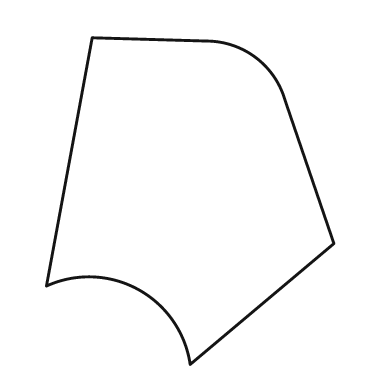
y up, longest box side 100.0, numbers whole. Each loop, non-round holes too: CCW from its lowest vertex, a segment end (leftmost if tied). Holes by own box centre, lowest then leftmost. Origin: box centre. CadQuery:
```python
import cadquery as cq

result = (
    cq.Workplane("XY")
    .moveTo(0.0, -50.0)
    .lineTo(44.0, -13.0)
    .lineTo(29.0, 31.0)
    .threePointArc((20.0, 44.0), (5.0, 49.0))
    .lineTo(-30.0, 50.0)
    .lineTo(-44.0, -26.0)
    .threePointArc((-16.0, -27.0), (0.0, -50.0))
    .close()
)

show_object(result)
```